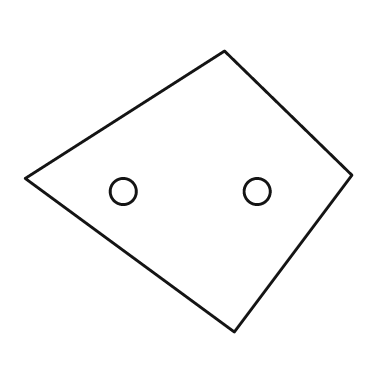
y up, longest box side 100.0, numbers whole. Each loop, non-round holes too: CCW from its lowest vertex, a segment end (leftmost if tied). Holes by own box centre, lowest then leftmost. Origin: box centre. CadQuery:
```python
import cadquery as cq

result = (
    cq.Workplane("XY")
    .moveTo(14.0, -43.0)
    .lineTo(50.0, 5.0)
    .lineTo(11.0, 43.0)
    .lineTo(-50.0, 4.0)
    .close()
    .moveTo(-20.0, 0.0)
    .circle(4.0)
    .moveTo(21.0, 0.0)
    .circle(4.0)
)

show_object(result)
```